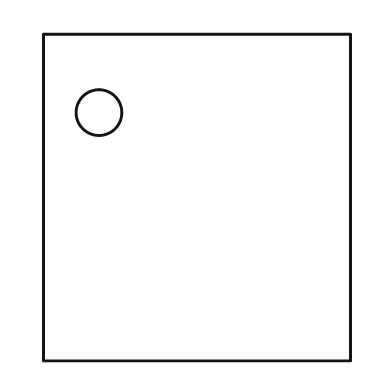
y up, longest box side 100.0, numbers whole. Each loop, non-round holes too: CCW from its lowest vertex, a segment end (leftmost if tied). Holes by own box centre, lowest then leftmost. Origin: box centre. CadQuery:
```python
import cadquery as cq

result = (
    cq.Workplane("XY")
    .moveTo(-47.0, -50.0)
    .lineTo(47.0, -50.0)
    .lineTo(47.0, 50.0)
    .lineTo(-47.0, 50.0)
    .close()
    .moveTo(-30.0, 26.0)
    .circle(7.0)
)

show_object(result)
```